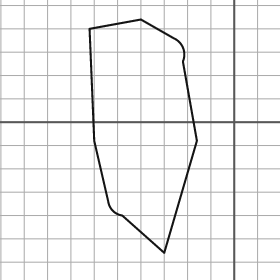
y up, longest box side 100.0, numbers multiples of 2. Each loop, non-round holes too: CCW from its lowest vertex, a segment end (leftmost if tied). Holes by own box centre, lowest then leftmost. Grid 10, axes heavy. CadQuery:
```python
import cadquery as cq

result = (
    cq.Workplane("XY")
    .moveTo(-30.0, -56.0)
    .lineTo(-16.0, -8.0)
    .lineTo(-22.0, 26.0)
    .threePointArc((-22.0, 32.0), (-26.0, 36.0))
    .lineTo(-40.0, 44.0)
    .lineTo(-62.0, 40.0)
    .lineTo(-60.0, -8.0)
    .lineTo(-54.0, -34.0)
    .threePointArc((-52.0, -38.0), (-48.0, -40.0))
    .close()
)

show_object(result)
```